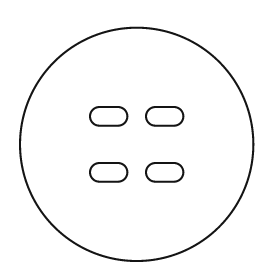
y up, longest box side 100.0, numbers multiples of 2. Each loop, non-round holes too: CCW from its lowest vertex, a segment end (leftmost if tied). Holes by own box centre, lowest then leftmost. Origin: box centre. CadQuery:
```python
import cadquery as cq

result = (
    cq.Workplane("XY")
    .moveTo(0.0, 0.0)
    .circle(50.0)
    .moveTo(-16.0, -16.0)
    .lineTo(-8.0, -16.0)
    .threePointArc((-4.0, -12.0), (-8.0, -8.0))
    .lineTo(-16.0, -8.0)
    .threePointArc((-20.0, -12.0), (-16.0, -16.0))
    .close()
    .moveTo(8.0, -16.0)
    .lineTo(16.0, -16.0)
    .threePointArc((20.0, -12.0), (16.0, -8.0))
    .lineTo(8.0, -8.0)
    .threePointArc((4.0, -12.0), (8.0, -16.0))
    .close()
    .moveTo(-16.0, 8.0)
    .lineTo(-8.0, 8.0)
    .threePointArc((-4.0, 12.0), (-8.0, 16.0))
    .lineTo(-16.0, 16.0)
    .threePointArc((-20.0, 12.0), (-16.0, 8.0))
    .close()
    .moveTo(8.0, 8.0)
    .lineTo(16.0, 8.0)
    .threePointArc((20.0, 12.0), (16.0, 16.0))
    .lineTo(8.0, 16.0)
    .threePointArc((4.0, 12.0), (8.0, 8.0))
    .close()
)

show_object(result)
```